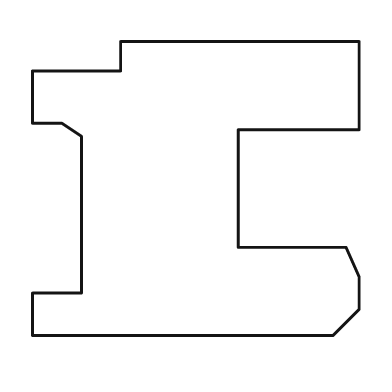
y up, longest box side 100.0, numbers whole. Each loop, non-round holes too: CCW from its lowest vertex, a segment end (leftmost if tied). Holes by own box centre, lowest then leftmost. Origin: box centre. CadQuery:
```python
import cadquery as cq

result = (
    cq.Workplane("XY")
    .moveTo(-50.0, -45.0)
    .lineTo(42.0, -45.0)
    .lineTo(50.0, -37.0)
    .lineTo(50.0, -27.0)
    .lineTo(46.0, -18.0)
    .lineTo(13.0, -18.0)
    .lineTo(13.0, 18.0)
    .lineTo(50.0, 18.0)
    .lineTo(50.0, 45.0)
    .lineTo(-23.0, 45.0)
    .lineTo(-23.0, 36.0)
    .lineTo(-50.0, 36.0)
    .lineTo(-50.0, 20.0)
    .lineTo(-41.0, 20.0)
    .lineTo(-35.0, 16.0)
    .lineTo(-35.0, -32.0)
    .lineTo(-50.0, -32.0)
    .close()
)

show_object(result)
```